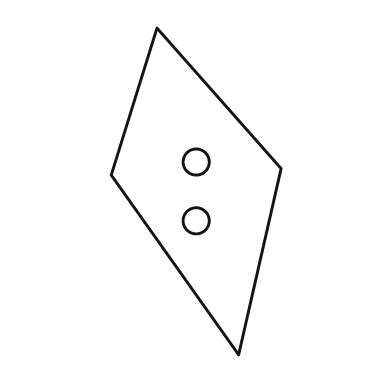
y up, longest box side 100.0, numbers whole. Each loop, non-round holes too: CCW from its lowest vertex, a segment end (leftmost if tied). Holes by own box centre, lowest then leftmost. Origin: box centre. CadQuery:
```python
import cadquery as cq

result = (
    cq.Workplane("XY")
    .moveTo(13.0, -50.0)
    .lineTo(26.0, 7.0)
    .lineTo(-12.0, 50.0)
    .lineTo(-26.0, 5.0)
    .close()
    .moveTo(0.0, -9.0)
    .circle(4.0)
    .moveTo(0.0, 9.0)
    .circle(4.0)
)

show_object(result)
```